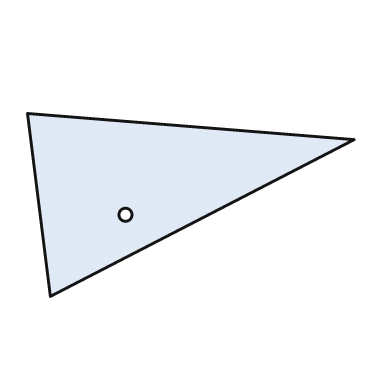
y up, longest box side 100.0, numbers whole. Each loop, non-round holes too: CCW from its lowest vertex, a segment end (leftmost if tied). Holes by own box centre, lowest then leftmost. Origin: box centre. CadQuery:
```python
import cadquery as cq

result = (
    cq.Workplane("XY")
    .moveTo(-43.0, -28.0)
    .lineTo(50.0, 20.0)
    .lineTo(-50.0, 28.0)
    .close()
    .moveTo(-20.0, -3.0)
    .circle(2.0)
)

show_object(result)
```